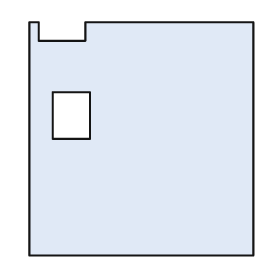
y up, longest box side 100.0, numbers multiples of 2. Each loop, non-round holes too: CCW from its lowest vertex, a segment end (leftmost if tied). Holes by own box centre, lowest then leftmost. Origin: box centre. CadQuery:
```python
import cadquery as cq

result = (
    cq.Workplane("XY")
    .moveTo(-48.0, -50.0)
    .lineTo(48.0, -50.0)
    .lineTo(48.0, 50.0)
    .lineTo(-24.0, 50.0)
    .lineTo(-24.0, 42.0)
    .lineTo(-44.0, 42.0)
    .lineTo(-44.0, 50.0)
    .lineTo(-48.0, 50.0)
    .close()
    .moveTo(-38.0, 0.0)
    .lineTo(-22.0, 0.0)
    .lineTo(-22.0, 20.0)
    .lineTo(-38.0, 20.0)
    .close()
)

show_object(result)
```